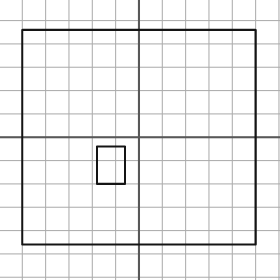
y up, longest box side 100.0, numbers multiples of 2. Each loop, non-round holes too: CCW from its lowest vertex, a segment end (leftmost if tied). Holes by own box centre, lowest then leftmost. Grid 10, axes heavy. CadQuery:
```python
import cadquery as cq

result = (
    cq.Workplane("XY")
    .moveTo(-50.0, -46.0)
    .lineTo(50.0, -46.0)
    .lineTo(50.0, 46.0)
    .lineTo(-50.0, 46.0)
    .close()
    .moveTo(-18.0, -20.0)
    .lineTo(-6.0, -20.0)
    .lineTo(-6.0, -4.0)
    .lineTo(-18.0, -4.0)
    .close()
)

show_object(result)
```